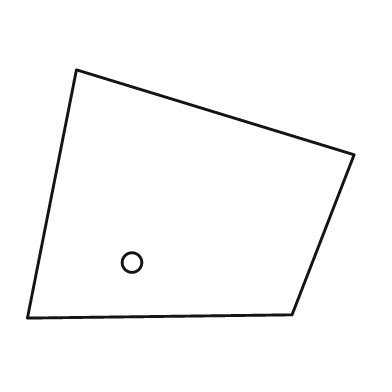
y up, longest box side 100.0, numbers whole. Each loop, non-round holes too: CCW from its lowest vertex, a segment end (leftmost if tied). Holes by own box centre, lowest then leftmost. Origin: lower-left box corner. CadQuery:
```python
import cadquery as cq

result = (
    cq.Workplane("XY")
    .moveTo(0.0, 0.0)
    .lineTo(81.0, 1.0)
    .lineTo(100.0, 50.0)
    .lineTo(15.0, 76.0)
    .close()
    .moveTo(32.0, 17.0)
    .circle(3.0)
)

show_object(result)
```